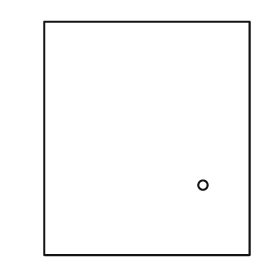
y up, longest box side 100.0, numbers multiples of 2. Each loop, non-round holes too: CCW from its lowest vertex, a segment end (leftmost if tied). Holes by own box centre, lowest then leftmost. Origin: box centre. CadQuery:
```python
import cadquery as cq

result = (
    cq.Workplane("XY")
    .moveTo(-44.0, -50.0)
    .lineTo(44.0, -50.0)
    .lineTo(44.0, 50.0)
    .lineTo(-44.0, 50.0)
    .close()
    .moveTo(24.0, -20.0)
    .circle(2.0)
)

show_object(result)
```